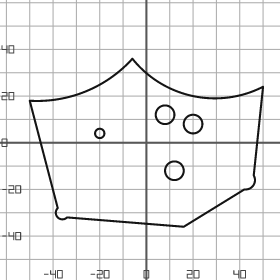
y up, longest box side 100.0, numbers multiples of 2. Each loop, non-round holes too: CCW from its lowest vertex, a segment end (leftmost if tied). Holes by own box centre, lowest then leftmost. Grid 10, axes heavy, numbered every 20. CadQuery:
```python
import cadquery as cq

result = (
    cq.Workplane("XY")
    .moveTo(16.0, -36.0)
    .lineTo(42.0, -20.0)
    .threePointArc((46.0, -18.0), (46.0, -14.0))
    .lineTo(50.0, 24.0)
    .threePointArc((20.0, 20.0), (-6.0, 36.0))
    .threePointArc((-26.0, 22.0), (-50.0, 18.0))
    .lineTo(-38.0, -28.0)
    .threePointArc((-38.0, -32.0), (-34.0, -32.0))
    .close()
    .moveTo(12.0, -12.0)
    .circle(4.0)
    .moveTo(-20.0, 4.0)
    .circle(2.0)
    .moveTo(20.0, 8.0)
    .circle(4.0)
    .moveTo(8.0, 12.0)
    .circle(4.0)
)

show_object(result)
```